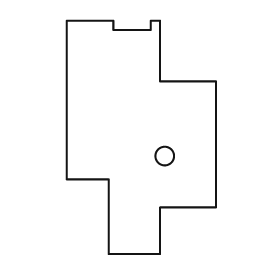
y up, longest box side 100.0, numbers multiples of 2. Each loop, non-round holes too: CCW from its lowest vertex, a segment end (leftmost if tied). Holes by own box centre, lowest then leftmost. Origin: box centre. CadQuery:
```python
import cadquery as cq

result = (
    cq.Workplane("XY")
    .moveTo(-14.0, -50.0)
    .lineTo(8.0, -50.0)
    .lineTo(8.0, -30.0)
    .lineTo(32.0, -30.0)
    .lineTo(32.0, 24.0)
    .lineTo(8.0, 24.0)
    .lineTo(8.0, 50.0)
    .lineTo(4.0, 50.0)
    .lineTo(4.0, 46.0)
    .lineTo(-12.0, 46.0)
    .lineTo(-12.0, 50.0)
    .lineTo(-32.0, 50.0)
    .lineTo(-32.0, -18.0)
    .lineTo(-14.0, -18.0)
    .close()
    .moveTo(10.0, -8.0)
    .circle(4.0)
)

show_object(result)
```